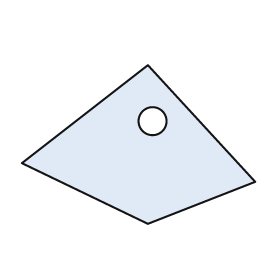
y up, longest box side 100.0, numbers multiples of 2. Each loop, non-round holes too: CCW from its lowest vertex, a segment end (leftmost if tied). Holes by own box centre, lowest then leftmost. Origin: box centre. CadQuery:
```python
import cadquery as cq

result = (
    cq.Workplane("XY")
    .moveTo(4.0, -34.0)
    .lineTo(50.0, -16.0)
    .lineTo(4.0, 34.0)
    .lineTo(-50.0, -8.0)
    .close()
    .moveTo(6.0, 10.0)
    .circle(6.0)
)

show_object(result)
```